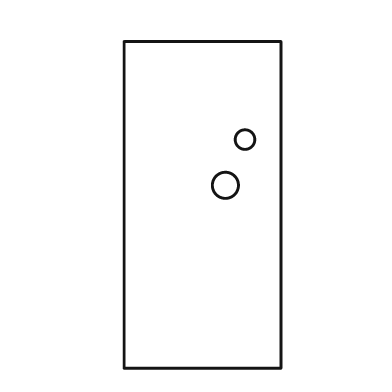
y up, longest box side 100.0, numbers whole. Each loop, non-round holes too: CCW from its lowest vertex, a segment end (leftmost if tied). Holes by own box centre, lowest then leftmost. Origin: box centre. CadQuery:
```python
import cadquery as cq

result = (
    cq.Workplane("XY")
    .moveTo(-24.0, -50.0)
    .lineTo(24.0, -50.0)
    .lineTo(24.0, 50.0)
    .lineTo(-24.0, 50.0)
    .close()
    .moveTo(7.0, 6.0)
    .circle(4.0)
    .moveTo(13.0, 20.0)
    .circle(3.0)
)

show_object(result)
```